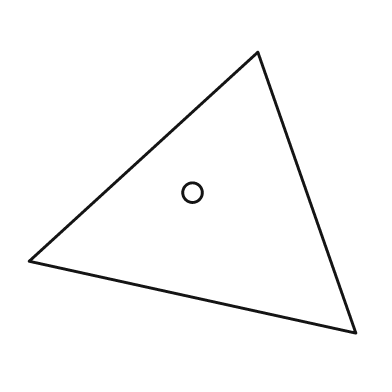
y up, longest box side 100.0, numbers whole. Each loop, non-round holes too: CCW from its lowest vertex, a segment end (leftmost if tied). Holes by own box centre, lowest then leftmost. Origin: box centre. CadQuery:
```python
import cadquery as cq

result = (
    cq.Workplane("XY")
    .moveTo(50.0, -43.0)
    .lineTo(20.0, 43.0)
    .lineTo(-50.0, -21.0)
    .close()
    .moveTo(0.0, 0.0)
    .circle(3.0)
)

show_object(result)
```